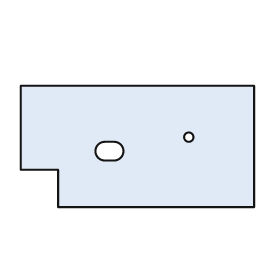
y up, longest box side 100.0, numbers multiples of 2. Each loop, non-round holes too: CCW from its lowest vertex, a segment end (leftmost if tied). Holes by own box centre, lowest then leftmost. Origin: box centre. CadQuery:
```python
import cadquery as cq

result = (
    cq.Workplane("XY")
    .moveTo(-34.0, -26.0)
    .lineTo(50.0, -26.0)
    .lineTo(50.0, 26.0)
    .lineTo(-50.0, 26.0)
    .lineTo(-50.0, -10.0)
    .lineTo(-34.0, -10.0)
    .close()
    .moveTo(-14.0, -6.0)
    .lineTo(-10.0, -6.0)
    .threePointArc((-6.0, -2.0), (-10.0, 2.0))
    .lineTo(-14.0, 2.0)
    .threePointArc((-18.0, -2.0), (-14.0, -6.0))
    .close()
    .moveTo(22.0, 4.0)
    .circle(2.0)
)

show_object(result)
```